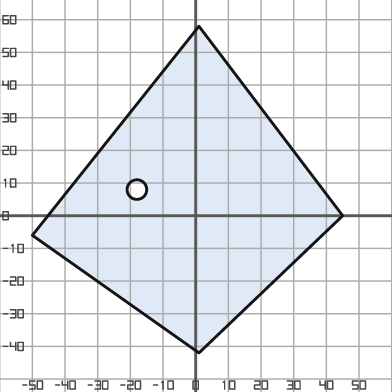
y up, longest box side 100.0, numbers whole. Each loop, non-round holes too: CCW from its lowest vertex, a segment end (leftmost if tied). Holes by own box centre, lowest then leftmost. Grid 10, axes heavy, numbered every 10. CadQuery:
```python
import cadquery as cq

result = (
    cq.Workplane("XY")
    .moveTo(1.0, -42.0)
    .lineTo(45.0, 0.0)
    .lineTo(1.0, 58.0)
    .lineTo(-50.0, -6.0)
    .close()
    .moveTo(-18.0, 8.0)
    .circle(3.0)
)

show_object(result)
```